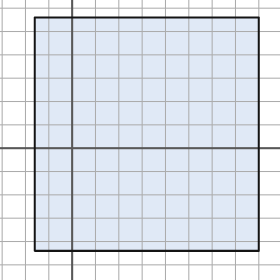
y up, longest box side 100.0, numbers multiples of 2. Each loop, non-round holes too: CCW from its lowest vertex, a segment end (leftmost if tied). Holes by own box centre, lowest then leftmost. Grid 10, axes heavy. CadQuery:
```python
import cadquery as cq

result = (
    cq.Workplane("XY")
    .moveTo(-16.0, -44.0)
    .lineTo(80.0, -44.0)
    .lineTo(80.0, 56.0)
    .lineTo(-16.0, 56.0)
    .close()
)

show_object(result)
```